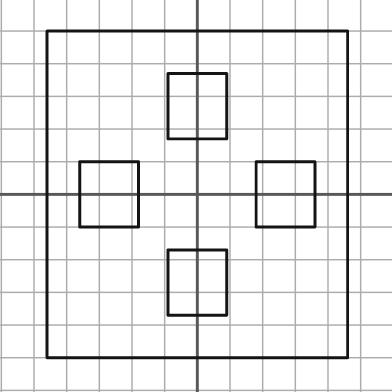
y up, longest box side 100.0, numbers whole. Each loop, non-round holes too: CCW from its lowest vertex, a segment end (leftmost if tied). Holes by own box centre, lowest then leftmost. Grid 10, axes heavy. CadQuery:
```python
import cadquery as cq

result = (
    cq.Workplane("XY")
    .moveTo(-46.0, -50.0)
    .lineTo(46.0, -50.0)
    .lineTo(46.0, 50.0)
    .lineTo(-46.0, 50.0)
    .close()
    .moveTo(-9.0, -37.0)
    .lineTo(9.0, -37.0)
    .lineTo(9.0, -17.0)
    .lineTo(-9.0, -17.0)
    .close()
    .moveTo(-36.0, -10.0)
    .lineTo(-18.0, -10.0)
    .lineTo(-18.0, 10.0)
    .lineTo(-36.0, 10.0)
    .close()
    .moveTo(18.0, -10.0)
    .lineTo(36.0, -10.0)
    .lineTo(36.0, 10.0)
    .lineTo(18.0, 10.0)
    .close()
    .moveTo(-9.0, 17.0)
    .lineTo(9.0, 17.0)
    .lineTo(9.0, 37.0)
    .lineTo(-9.0, 37.0)
    .close()
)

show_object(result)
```